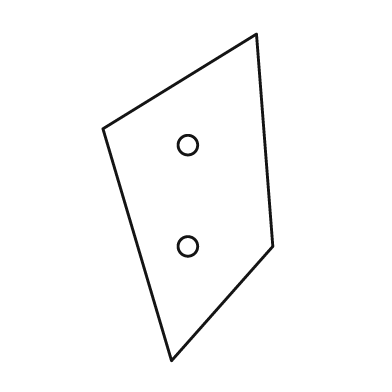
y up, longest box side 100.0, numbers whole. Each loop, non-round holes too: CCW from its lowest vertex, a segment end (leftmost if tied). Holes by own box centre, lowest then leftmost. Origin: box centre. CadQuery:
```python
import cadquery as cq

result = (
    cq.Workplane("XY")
    .moveTo(-5.0, -50.0)
    .lineTo(26.0, -15.0)
    .lineTo(21.0, 50.0)
    .lineTo(-26.0, 21.0)
    .close()
    .moveTo(0.0, -15.0)
    .circle(3.0)
    .moveTo(0.0, 16.0)
    .circle(3.0)
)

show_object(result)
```